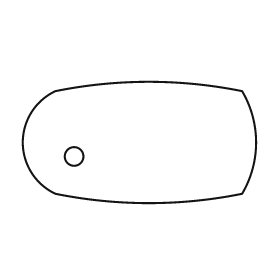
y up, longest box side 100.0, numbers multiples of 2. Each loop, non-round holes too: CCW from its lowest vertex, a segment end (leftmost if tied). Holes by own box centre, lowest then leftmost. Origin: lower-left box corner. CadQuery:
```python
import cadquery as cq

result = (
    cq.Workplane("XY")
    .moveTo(14.0, 4.0)
    .threePointArc((54.0, 0.0), (94.0, 4.0))
    .threePointArc((100.0, 26.0), (94.0, 48.0))
    .threePointArc((54.0, 52.0), (14.0, 48.0))
    .threePointArc((0.0, 26.0), (14.0, 4.0))
    .close()
    .moveTo(22.0, 20.0)
    .circle(4.0)
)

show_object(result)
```